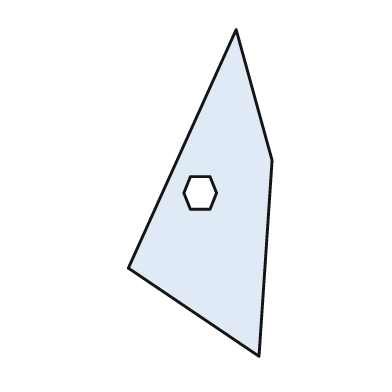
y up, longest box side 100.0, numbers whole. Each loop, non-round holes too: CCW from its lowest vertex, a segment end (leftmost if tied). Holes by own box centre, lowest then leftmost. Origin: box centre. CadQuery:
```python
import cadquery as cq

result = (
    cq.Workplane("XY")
    .moveTo(18.0, -50.0)
    .lineTo(22.0, 10.0)
    .lineTo(11.0, 50.0)
    .lineTo(-22.0, -23.0)
    .close()
    .moveTo(-3.0, -5.0)
    .lineTo(3.0, -5.0)
    .lineTo(5.0, 0.0)
    .lineTo(3.0, 5.0)
    .lineTo(-3.0, 5.0)
    .lineTo(-5.0, 0.0)
    .close()
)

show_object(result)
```